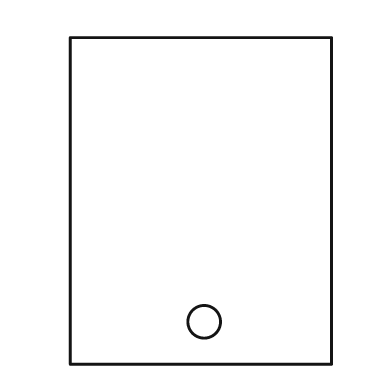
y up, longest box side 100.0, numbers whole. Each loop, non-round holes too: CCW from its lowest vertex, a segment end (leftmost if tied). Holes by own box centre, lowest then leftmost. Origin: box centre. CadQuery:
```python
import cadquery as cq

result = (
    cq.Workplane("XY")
    .moveTo(-40.0, -50.0)
    .lineTo(40.0, -50.0)
    .lineTo(40.0, 50.0)
    .lineTo(-40.0, 50.0)
    .close()
    .moveTo(1.0, -37.0)
    .circle(5.0)
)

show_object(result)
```